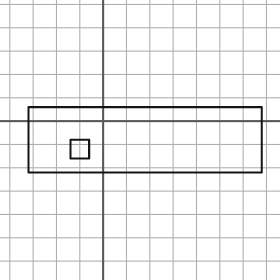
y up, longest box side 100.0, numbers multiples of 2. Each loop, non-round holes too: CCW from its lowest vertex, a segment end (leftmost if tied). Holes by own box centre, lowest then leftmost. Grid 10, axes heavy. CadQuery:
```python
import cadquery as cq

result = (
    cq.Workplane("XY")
    .moveTo(-32.0, -22.0)
    .lineTo(68.0, -22.0)
    .lineTo(68.0, 6.0)
    .lineTo(-32.0, 6.0)
    .close()
    .moveTo(-14.0, -16.0)
    .lineTo(-6.0, -16.0)
    .lineTo(-6.0, -8.0)
    .lineTo(-14.0, -8.0)
    .close()
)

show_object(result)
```